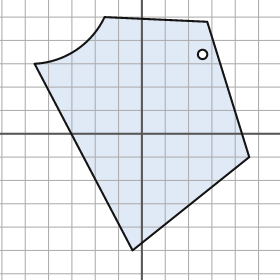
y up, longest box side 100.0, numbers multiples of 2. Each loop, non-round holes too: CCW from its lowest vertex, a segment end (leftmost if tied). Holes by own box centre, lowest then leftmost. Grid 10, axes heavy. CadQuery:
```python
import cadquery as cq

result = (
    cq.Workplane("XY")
    .moveTo(-4.0, -50.0)
    .lineTo(46.0, -10.0)
    .lineTo(28.0, 48.0)
    .lineTo(-16.0, 50.0)
    .threePointArc((-28.0, 36.0), (-46.0, 30.0))
    .close()
    .moveTo(26.0, 34.0)
    .circle(2.0)
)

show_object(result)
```